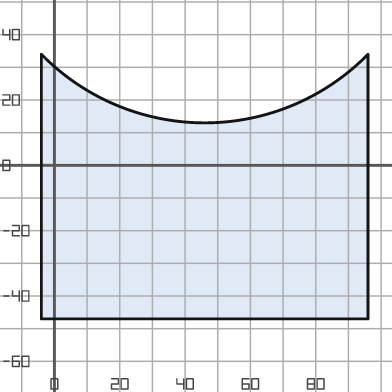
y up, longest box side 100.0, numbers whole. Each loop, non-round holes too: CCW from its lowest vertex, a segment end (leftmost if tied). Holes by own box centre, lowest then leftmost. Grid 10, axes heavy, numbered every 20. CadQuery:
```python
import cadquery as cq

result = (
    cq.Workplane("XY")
    .moveTo(-4.0, -47.0)
    .lineTo(96.0, -47.0)
    .lineTo(96.0, 34.0)
    .threePointArc((46.0, 13.0), (-4.0, 34.0))
    .close()
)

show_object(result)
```